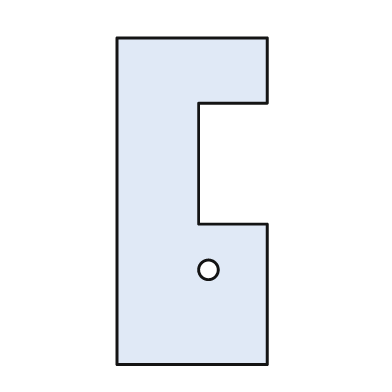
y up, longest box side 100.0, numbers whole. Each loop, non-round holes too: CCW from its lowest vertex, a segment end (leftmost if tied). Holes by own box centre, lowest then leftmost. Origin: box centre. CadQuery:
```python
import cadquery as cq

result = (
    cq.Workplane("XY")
    .moveTo(-23.0, -50.0)
    .lineTo(23.0, -50.0)
    .lineTo(23.0, -7.0)
    .lineTo(2.0, -7.0)
    .lineTo(2.0, 30.0)
    .lineTo(23.0, 30.0)
    .lineTo(23.0, 50.0)
    .lineTo(-23.0, 50.0)
    .close()
    .moveTo(5.0, -21.0)
    .circle(3.0)
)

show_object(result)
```